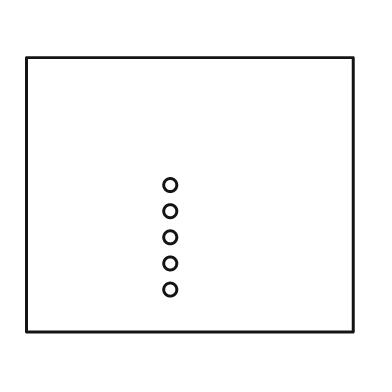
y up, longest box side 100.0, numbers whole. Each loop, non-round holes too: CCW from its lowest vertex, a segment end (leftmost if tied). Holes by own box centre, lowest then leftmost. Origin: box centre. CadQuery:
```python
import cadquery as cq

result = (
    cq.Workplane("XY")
    .moveTo(-50.0, -42.0)
    .lineTo(50.0, -42.0)
    .lineTo(50.0, 42.0)
    .lineTo(-50.0, 42.0)
    .close()
    .moveTo(-6.0, -29.0)
    .circle(2.0)
    .moveTo(-6.0, -21.0)
    .circle(2.0)
    .moveTo(-6.0, -13.0)
    .circle(2.0)
    .moveTo(-6.0, -5.0)
    .circle(2.0)
    .moveTo(-6.0, 3.0)
    .circle(2.0)
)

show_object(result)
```